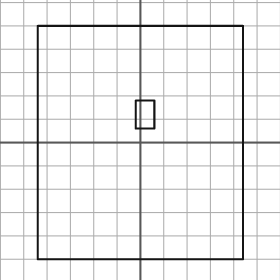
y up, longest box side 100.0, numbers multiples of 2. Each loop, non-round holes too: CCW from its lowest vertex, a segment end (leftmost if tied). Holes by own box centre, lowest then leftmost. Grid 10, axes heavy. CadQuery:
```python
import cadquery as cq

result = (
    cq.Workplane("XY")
    .moveTo(-44.0, -50.0)
    .lineTo(44.0, -50.0)
    .lineTo(44.0, 50.0)
    .lineTo(-44.0, 50.0)
    .close()
    .moveTo(-2.0, 6.0)
    .lineTo(6.0, 6.0)
    .lineTo(6.0, 18.0)
    .lineTo(-2.0, 18.0)
    .close()
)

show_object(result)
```